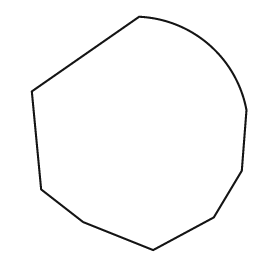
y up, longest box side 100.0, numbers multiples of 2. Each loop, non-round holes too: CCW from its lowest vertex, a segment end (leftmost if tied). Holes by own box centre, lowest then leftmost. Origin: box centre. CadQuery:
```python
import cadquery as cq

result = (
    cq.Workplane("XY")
    .moveTo(6.0, -50.0)
    .lineTo(32.0, -36.0)
    .lineTo(44.0, -16.0)
    .lineTo(46.0, 10.0)
    .threePointArc((30.0, 38.0), (0.0, 50.0))
    .lineTo(-46.0, 18.0)
    .lineTo(-42.0, -24.0)
    .lineTo(-24.0, -38.0)
    .close()
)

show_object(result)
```